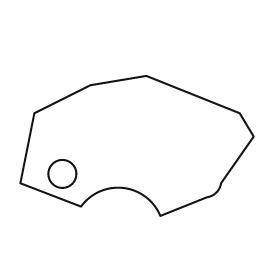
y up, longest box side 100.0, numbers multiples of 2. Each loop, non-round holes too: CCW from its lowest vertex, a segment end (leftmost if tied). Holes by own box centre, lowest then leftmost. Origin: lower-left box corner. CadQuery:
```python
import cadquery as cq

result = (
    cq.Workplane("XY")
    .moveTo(60.0, 0.0)
    .lineTo(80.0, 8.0)
    .threePointArc((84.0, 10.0), (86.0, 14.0))
    .lineTo(100.0, 34.0)
    .lineTo(94.0, 44.0)
    .lineTo(54.0, 60.0)
    .lineTo(30.0, 56.0)
    .lineTo(6.0, 44.0)
    .lineTo(0.0, 14.0)
    .lineTo(26.0, 4.0)
    .threePointArc((44.0, 12.0), (60.0, 0.0))
    .close()
    .moveTo(18.0, 18.0)
    .circle(6.0)
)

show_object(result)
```